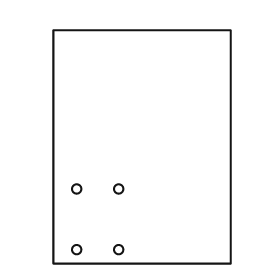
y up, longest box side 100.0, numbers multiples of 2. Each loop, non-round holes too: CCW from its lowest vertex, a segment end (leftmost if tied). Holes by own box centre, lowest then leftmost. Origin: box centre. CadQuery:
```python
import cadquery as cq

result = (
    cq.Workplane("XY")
    .moveTo(-38.0, -50.0)
    .lineTo(38.0, -50.0)
    .lineTo(38.0, 50.0)
    .lineTo(-38.0, 50.0)
    .close()
    .moveTo(-28.0, -44.0)
    .circle(2.0)
    .moveTo(-10.0, -44.0)
    .circle(2.0)
    .moveTo(-28.0, -18.0)
    .circle(2.0)
    .moveTo(-10.0, -18.0)
    .circle(2.0)
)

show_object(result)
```